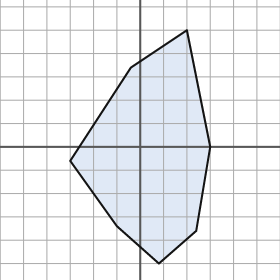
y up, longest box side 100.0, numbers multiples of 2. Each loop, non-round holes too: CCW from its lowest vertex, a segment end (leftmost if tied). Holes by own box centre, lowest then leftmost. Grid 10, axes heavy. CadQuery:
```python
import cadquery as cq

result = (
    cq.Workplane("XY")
    .moveTo(8.0, -50.0)
    .lineTo(24.0, -36.0)
    .lineTo(30.0, 0.0)
    .lineTo(20.0, 50.0)
    .lineTo(-4.0, 34.0)
    .lineTo(-30.0, -6.0)
    .lineTo(-10.0, -34.0)
    .close()
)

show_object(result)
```